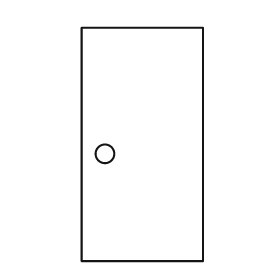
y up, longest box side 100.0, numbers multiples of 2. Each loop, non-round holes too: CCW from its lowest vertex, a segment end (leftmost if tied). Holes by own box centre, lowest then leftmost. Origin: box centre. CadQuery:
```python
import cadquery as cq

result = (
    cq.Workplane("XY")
    .moveTo(-26.0, -50.0)
    .lineTo(26.0, -50.0)
    .lineTo(26.0, 50.0)
    .lineTo(-26.0, 50.0)
    .close()
    .moveTo(-16.0, -4.0)
    .circle(4.0)
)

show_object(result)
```